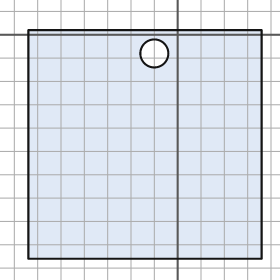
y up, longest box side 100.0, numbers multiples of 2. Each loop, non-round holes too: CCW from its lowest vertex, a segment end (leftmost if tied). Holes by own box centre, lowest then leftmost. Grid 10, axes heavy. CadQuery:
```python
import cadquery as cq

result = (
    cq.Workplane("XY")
    .moveTo(-64.0, -96.0)
    .lineTo(36.0, -96.0)
    .lineTo(36.0, 2.0)
    .lineTo(-64.0, 2.0)
    .close()
    .moveTo(-10.0, -8.0)
    .circle(6.0)
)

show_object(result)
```